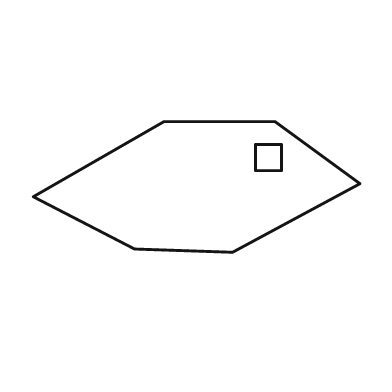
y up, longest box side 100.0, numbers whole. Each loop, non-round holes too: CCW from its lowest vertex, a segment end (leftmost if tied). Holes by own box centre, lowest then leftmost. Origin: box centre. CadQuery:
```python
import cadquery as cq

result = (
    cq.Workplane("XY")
    .moveTo(11.0, -20.0)
    .lineTo(50.0, 1.0)
    .lineTo(24.0, 20.0)
    .lineTo(-10.0, 20.0)
    .lineTo(-50.0, -3.0)
    .lineTo(-19.0, -19.0)
    .close()
    .moveTo(18.0, 5.0)
    .lineTo(26.0, 5.0)
    .lineTo(26.0, 13.0)
    .lineTo(18.0, 13.0)
    .close()
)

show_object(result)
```